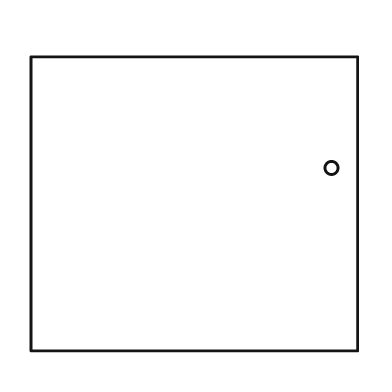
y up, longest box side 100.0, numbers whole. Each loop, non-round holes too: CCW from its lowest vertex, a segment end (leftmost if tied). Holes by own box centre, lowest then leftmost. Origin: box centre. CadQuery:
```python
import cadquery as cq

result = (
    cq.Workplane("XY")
    .moveTo(-50.0, -45.0)
    .lineTo(50.0, -45.0)
    .lineTo(50.0, 45.0)
    .lineTo(-50.0, 45.0)
    .close()
    .moveTo(42.0, 11.0)
    .circle(2.0)
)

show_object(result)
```